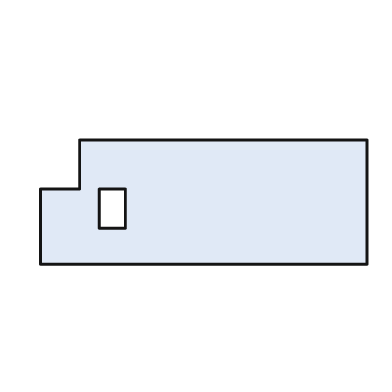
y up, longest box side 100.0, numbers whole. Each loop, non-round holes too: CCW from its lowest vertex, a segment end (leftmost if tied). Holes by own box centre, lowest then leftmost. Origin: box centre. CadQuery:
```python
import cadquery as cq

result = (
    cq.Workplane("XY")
    .moveTo(-50.0, -19.0)
    .lineTo(50.0, -19.0)
    .lineTo(50.0, 19.0)
    .lineTo(-38.0, 19.0)
    .lineTo(-38.0, 4.0)
    .lineTo(-50.0, 4.0)
    .close()
    .moveTo(-32.0, -8.0)
    .lineTo(-24.0, -8.0)
    .lineTo(-24.0, 4.0)
    .lineTo(-32.0, 4.0)
    .close()
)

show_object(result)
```